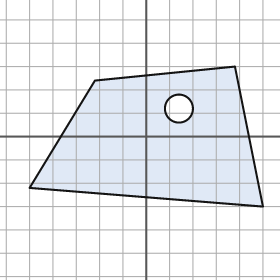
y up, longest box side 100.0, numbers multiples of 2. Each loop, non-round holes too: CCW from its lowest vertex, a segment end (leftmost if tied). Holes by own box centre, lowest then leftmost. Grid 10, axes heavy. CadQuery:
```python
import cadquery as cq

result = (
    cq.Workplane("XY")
    .moveTo(50.0, -30.0)
    .lineTo(38.0, 30.0)
    .lineTo(-22.0, 24.0)
    .lineTo(-50.0, -22.0)
    .close()
    .moveTo(14.0, 12.0)
    .circle(6.0)
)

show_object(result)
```